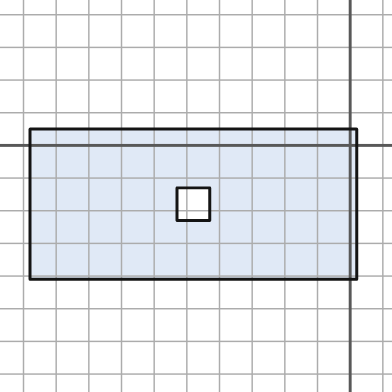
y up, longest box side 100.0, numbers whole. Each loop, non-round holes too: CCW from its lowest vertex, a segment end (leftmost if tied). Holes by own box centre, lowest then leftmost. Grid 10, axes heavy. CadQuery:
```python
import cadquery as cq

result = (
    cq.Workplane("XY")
    .moveTo(-98.0, -41.0)
    .lineTo(2.0, -41.0)
    .lineTo(2.0, 5.0)
    .lineTo(-98.0, 5.0)
    .close()
    .moveTo(-53.0, -23.0)
    .lineTo(-43.0, -23.0)
    .lineTo(-43.0, -13.0)
    .lineTo(-53.0, -13.0)
    .close()
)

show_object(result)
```